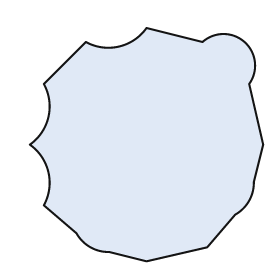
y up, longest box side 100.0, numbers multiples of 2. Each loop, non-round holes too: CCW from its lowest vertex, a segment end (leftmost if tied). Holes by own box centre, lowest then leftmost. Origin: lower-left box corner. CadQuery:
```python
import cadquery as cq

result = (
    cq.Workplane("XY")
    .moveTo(50.0, 0.0)
    .lineTo(76.0, 6.0)
    .lineTo(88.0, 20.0)
    .threePointArc((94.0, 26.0), (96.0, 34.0))
    .lineTo(100.0, 50.0)
    .lineTo(94.0, 76.0)
    .threePointArc((92.0, 94.0), (74.0, 94.0))
    .lineTo(50.0, 100.0)
    .threePointArc((38.0, 92.0), (24.0, 94.0))
    .lineTo(6.0, 76.0)
    .threePointArc((8.0, 62.0), (0.0, 50.0))
    .threePointArc((8.0, 38.0), (6.0, 24.0))
    .lineTo(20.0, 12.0)
    .threePointArc((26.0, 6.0), (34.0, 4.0))
    .close()
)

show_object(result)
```